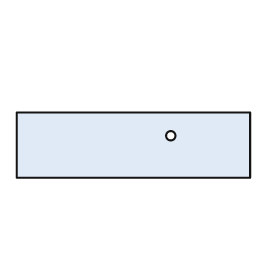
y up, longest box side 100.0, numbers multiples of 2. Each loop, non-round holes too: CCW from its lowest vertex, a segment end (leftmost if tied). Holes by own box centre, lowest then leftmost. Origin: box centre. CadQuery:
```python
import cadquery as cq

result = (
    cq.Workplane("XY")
    .moveTo(-50.0, -14.0)
    .lineTo(50.0, -14.0)
    .lineTo(50.0, 14.0)
    .lineTo(-50.0, 14.0)
    .close()
    .moveTo(16.0, 4.0)
    .circle(2.0)
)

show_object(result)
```